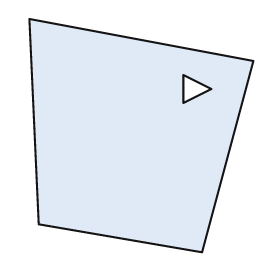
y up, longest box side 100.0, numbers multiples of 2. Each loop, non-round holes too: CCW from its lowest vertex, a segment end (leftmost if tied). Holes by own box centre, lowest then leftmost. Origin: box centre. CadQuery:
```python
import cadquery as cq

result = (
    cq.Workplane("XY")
    .moveTo(26.0, -50.0)
    .lineTo(48.0, 32.0)
    .lineTo(-48.0, 50.0)
    .lineTo(-44.0, -38.0)
    .close()
    .moveTo(18.0, 14.0)
    .lineTo(30.0, 20.0)
    .lineTo(18.0, 26.0)
    .close()
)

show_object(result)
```